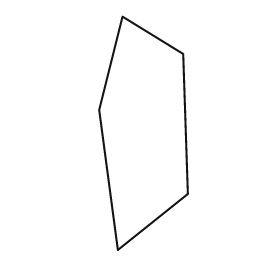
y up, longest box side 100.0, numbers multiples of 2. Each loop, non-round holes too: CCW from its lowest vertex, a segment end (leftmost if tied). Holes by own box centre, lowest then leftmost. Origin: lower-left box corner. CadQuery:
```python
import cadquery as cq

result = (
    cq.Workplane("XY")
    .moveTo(8.0, 0.0)
    .lineTo(38.0, 24.0)
    .lineTo(36.0, 84.0)
    .lineTo(10.0, 100.0)
    .lineTo(0.0, 60.0)
    .close()
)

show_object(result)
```